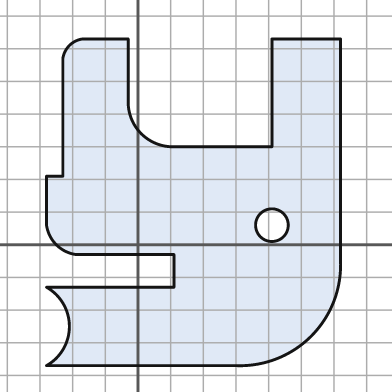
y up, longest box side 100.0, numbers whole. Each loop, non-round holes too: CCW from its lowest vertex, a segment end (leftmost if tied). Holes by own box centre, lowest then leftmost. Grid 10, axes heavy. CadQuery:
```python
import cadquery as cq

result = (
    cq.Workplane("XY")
    .moveTo(-28.0, -37.0)
    .lineTo(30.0, -37.0)
    .threePointArc((53.0, -28.0), (62.0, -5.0))
    .lineTo(62.0, 63.0)
    .lineTo(41.0, 63.0)
    .lineTo(41.0, 30.0)
    .lineTo(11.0, 30.0)
    .threePointArc((1.0, 34.0), (-3.0, 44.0))
    .lineTo(-3.0, 63.0)
    .lineTo(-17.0, 63.0)
    .threePointArc((-21.0, 61.0), (-23.0, 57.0))
    .lineTo(-23.0, 21.0)
    .lineTo(-28.0, 21.0)
    .lineTo(-28.0, 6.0)
    .threePointArc((-25.0, 0.0), (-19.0, -3.0))
    .lineTo(11.0, -3.0)
    .lineTo(11.0, -13.0)
    .lineTo(-28.0, -13.0)
    .threePointArc((-21.0, -25.0), (-28.0, -37.0))
    .close()
    .moveTo(41.0, 6.0)
    .circle(5.0)
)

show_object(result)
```